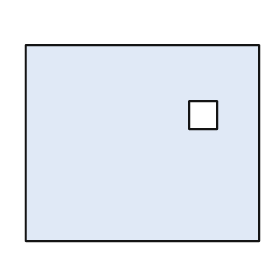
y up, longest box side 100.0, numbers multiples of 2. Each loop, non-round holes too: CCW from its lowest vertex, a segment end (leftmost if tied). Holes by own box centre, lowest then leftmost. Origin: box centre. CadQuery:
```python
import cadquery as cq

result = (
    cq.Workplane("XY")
    .moveTo(-50.0, -42.0)
    .lineTo(50.0, -42.0)
    .lineTo(50.0, 42.0)
    .lineTo(-50.0, 42.0)
    .close()
    .moveTo(20.0, 6.0)
    .lineTo(32.0, 6.0)
    .lineTo(32.0, 18.0)
    .lineTo(20.0, 18.0)
    .close()
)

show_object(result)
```